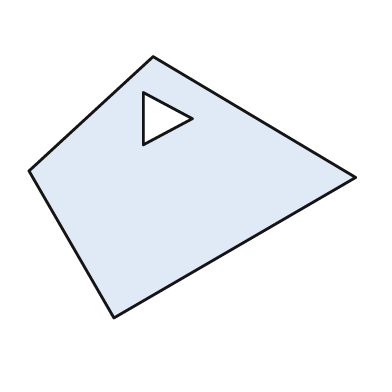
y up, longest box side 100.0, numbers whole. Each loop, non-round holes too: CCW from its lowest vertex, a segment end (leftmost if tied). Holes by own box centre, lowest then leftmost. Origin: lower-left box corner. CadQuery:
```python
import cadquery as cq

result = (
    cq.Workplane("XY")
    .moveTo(26.0, 0.0)
    .lineTo(100.0, 43.0)
    .lineTo(38.0, 80.0)
    .lineTo(0.0, 45.0)
    .close()
    .moveTo(35.0, 53.0)
    .lineTo(50.0, 61.0)
    .lineTo(35.0, 69.0)
    .close()
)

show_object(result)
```